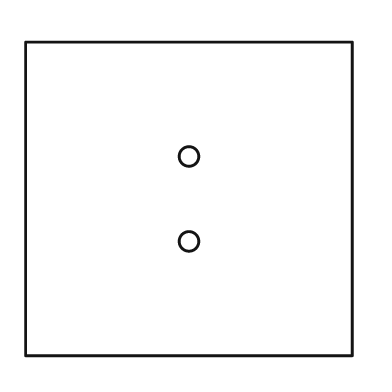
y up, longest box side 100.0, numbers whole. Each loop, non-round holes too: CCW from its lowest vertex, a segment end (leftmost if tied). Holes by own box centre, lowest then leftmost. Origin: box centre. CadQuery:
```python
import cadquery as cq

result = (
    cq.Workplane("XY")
    .moveTo(-50.0, -48.0)
    .lineTo(50.0, -48.0)
    .lineTo(50.0, 48.0)
    .lineTo(-50.0, 48.0)
    .close()
    .moveTo(0.0, -13.0)
    .circle(3.0)
    .moveTo(0.0, 13.0)
    .circle(3.0)
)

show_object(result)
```